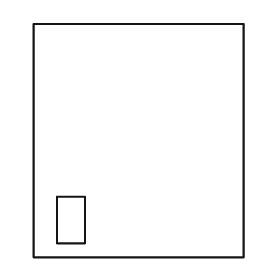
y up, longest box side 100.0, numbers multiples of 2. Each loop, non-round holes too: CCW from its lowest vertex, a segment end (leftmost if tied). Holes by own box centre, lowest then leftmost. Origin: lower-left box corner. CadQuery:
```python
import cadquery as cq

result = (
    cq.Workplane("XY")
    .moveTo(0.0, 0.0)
    .lineTo(90.0, 0.0)
    .lineTo(90.0, 100.0)
    .lineTo(0.0, 100.0)
    .close()
    .moveTo(10.0, 6.0)
    .lineTo(22.0, 6.0)
    .lineTo(22.0, 26.0)
    .lineTo(10.0, 26.0)
    .close()
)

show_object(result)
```